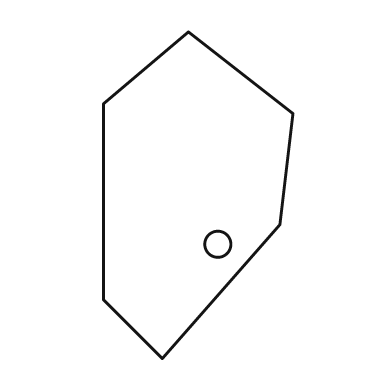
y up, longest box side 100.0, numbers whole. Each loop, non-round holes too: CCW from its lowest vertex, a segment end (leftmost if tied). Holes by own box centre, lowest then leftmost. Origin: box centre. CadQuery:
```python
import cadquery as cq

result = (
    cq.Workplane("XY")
    .moveTo(-11.0, -50.0)
    .lineTo(25.0, -9.0)
    .lineTo(29.0, 25.0)
    .lineTo(-3.0, 50.0)
    .lineTo(-29.0, 28.0)
    .lineTo(-29.0, -32.0)
    .close()
    .moveTo(6.0, -15.0)
    .circle(4.0)
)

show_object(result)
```